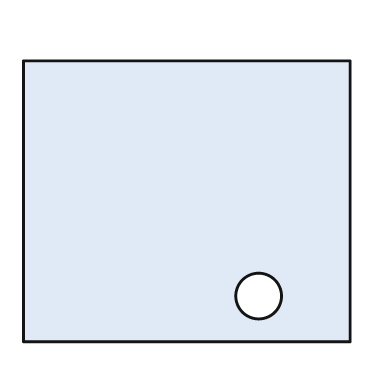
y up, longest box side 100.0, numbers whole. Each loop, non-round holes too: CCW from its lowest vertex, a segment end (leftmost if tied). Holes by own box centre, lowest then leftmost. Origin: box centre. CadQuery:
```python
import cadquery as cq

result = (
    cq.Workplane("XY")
    .moveTo(-50.0, -43.0)
    .lineTo(50.0, -43.0)
    .lineTo(50.0, 43.0)
    .lineTo(-50.0, 43.0)
    .close()
    .moveTo(22.0, -29.0)
    .circle(7.0)
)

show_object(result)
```